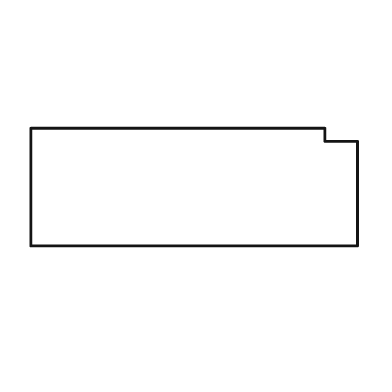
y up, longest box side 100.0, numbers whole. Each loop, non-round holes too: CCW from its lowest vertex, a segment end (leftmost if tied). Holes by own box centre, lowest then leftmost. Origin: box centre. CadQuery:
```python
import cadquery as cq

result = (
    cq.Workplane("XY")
    .moveTo(-50.0, -18.0)
    .lineTo(50.0, -18.0)
    .lineTo(50.0, 14.0)
    .lineTo(40.0, 14.0)
    .lineTo(40.0, 18.0)
    .lineTo(-50.0, 18.0)
    .close()
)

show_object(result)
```